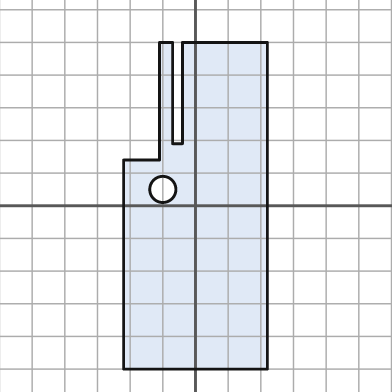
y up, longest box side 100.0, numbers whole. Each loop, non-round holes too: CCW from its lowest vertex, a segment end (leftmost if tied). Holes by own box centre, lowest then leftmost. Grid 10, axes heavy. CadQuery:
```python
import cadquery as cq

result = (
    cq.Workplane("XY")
    .moveTo(-22.0, -50.0)
    .lineTo(22.0, -50.0)
    .lineTo(22.0, 50.0)
    .lineTo(-4.0, 50.0)
    .lineTo(-4.0, 19.0)
    .lineTo(-7.0, 19.0)
    .lineTo(-7.0, 50.0)
    .lineTo(-11.0, 50.0)
    .lineTo(-11.0, 14.0)
    .lineTo(-22.0, 14.0)
    .close()
    .moveTo(-10.0, 5.0)
    .circle(4.0)
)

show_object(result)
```